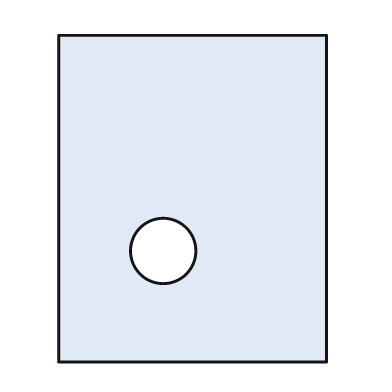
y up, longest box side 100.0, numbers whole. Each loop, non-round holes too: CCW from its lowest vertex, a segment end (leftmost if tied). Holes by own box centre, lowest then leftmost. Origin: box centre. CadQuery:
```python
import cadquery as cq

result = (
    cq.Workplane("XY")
    .moveTo(-41.0, -50.0)
    .lineTo(41.0, -50.0)
    .lineTo(41.0, 50.0)
    .lineTo(-41.0, 50.0)
    .close()
    .moveTo(-9.0, -16.0)
    .circle(10.0)
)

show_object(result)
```